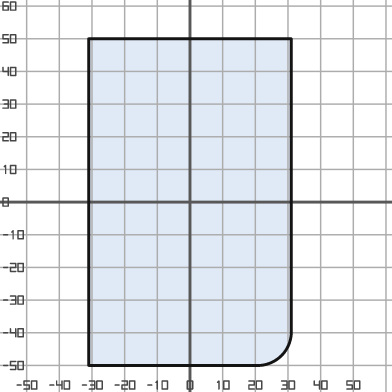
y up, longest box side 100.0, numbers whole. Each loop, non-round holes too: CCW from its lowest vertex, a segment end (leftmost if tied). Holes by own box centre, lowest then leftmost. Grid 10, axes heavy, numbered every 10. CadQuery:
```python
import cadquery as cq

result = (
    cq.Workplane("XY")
    .moveTo(-31.0, -50.0)
    .lineTo(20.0, -50.0)
    .threePointArc((28.0, -47.0), (31.0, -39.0))
    .lineTo(31.0, 50.0)
    .lineTo(-31.0, 50.0)
    .close()
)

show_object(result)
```